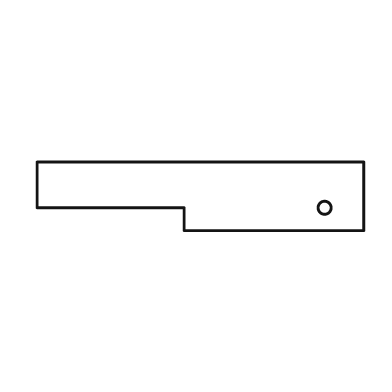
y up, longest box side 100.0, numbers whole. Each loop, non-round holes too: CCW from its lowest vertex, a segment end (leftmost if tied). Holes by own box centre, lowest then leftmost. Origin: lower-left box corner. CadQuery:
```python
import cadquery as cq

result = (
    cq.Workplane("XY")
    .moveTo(45.0, 0.0)
    .lineTo(100.0, 0.0)
    .lineTo(100.0, 21.0)
    .lineTo(0.0, 21.0)
    .lineTo(0.0, 7.0)
    .lineTo(45.0, 7.0)
    .close()
    .moveTo(88.0, 7.0)
    .circle(2.0)
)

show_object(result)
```